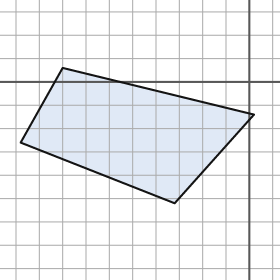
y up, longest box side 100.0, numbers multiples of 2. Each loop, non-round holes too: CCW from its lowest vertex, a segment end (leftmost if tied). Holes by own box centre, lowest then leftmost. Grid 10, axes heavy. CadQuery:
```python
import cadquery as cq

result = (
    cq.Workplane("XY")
    .moveTo(-32.0, -52.0)
    .lineTo(2.0, -14.0)
    .lineTo(-80.0, 6.0)
    .lineTo(-98.0, -26.0)
    .close()
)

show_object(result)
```